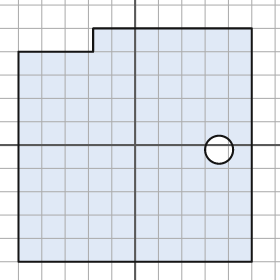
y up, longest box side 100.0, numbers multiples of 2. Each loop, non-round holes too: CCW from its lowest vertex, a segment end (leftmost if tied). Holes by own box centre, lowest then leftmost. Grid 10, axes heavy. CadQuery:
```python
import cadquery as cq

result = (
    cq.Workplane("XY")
    .moveTo(-50.0, -50.0)
    .lineTo(50.0, -50.0)
    .lineTo(50.0, 50.0)
    .lineTo(-18.0, 50.0)
    .lineTo(-18.0, 40.0)
    .lineTo(-50.0, 40.0)
    .close()
    .moveTo(36.0, -2.0)
    .circle(6.0)
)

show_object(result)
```